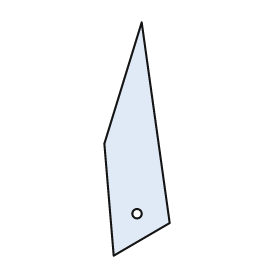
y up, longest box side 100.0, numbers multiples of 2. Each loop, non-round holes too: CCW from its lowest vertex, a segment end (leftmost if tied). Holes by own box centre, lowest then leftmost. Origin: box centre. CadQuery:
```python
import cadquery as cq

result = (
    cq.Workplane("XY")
    .moveTo(-10.0, -50.0)
    .lineTo(14.0, -36.0)
    .lineTo(2.0, 50.0)
    .lineTo(-14.0, -2.0)
    .close()
    .moveTo(0.0, -32.0)
    .circle(2.0)
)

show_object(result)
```